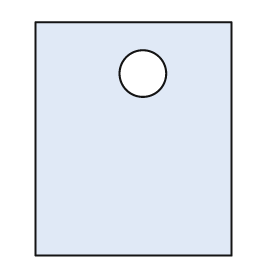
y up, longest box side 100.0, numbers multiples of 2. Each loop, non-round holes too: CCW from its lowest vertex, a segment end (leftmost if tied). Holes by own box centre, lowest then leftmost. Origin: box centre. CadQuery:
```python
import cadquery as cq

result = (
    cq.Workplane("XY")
    .moveTo(-42.0, -50.0)
    .lineTo(42.0, -50.0)
    .lineTo(42.0, 50.0)
    .lineTo(-42.0, 50.0)
    .close()
    .moveTo(4.0, 28.0)
    .circle(10.0)
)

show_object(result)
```